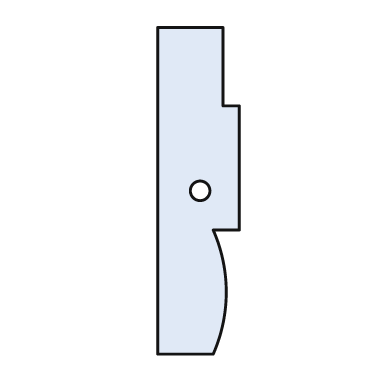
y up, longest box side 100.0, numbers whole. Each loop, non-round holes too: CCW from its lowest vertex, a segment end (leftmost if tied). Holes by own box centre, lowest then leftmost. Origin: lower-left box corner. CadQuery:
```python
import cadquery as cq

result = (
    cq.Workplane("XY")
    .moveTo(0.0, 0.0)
    .lineTo(17.0, 0.0)
    .threePointArc((21.0, 19.0), (17.0, 38.0))
    .lineTo(25.0, 38.0)
    .lineTo(25.0, 76.0)
    .lineTo(20.0, 76.0)
    .lineTo(20.0, 100.0)
    .lineTo(0.0, 100.0)
    .close()
    .moveTo(13.0, 50.0)
    .circle(3.0)
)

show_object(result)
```